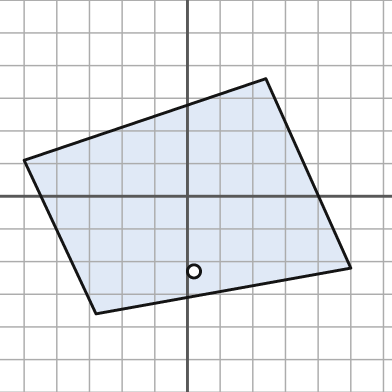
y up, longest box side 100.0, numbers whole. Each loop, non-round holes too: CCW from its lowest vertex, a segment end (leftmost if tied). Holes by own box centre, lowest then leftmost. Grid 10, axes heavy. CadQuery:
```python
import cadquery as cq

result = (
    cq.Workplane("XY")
    .moveTo(-28.0, -36.0)
    .lineTo(50.0, -22.0)
    .lineTo(24.0, 36.0)
    .lineTo(-50.0, 11.0)
    .close()
    .moveTo(2.0, -23.0)
    .circle(2.0)
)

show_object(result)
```